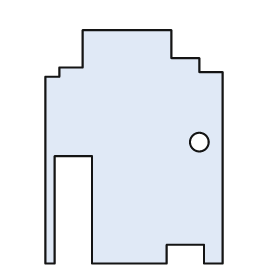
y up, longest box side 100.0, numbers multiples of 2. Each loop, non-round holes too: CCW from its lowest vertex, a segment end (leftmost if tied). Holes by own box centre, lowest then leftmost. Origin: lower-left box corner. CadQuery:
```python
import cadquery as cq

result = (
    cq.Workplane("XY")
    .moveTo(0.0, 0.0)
    .lineTo(4.0, 0.0)
    .lineTo(4.0, 46.0)
    .lineTo(20.0, 46.0)
    .lineTo(20.0, 0.0)
    .lineTo(52.0, 0.0)
    .lineTo(52.0, 8.0)
    .lineTo(68.0, 8.0)
    .lineTo(68.0, 0.0)
    .lineTo(76.0, 0.0)
    .lineTo(76.0, 82.0)
    .lineTo(66.0, 82.0)
    .lineTo(66.0, 88.0)
    .lineTo(54.0, 88.0)
    .lineTo(54.0, 100.0)
    .lineTo(16.0, 100.0)
    .lineTo(16.0, 84.0)
    .lineTo(6.0, 84.0)
    .lineTo(6.0, 80.0)
    .lineTo(0.0, 80.0)
    .close()
    .moveTo(66.0, 52.0)
    .circle(4.0)
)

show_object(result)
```